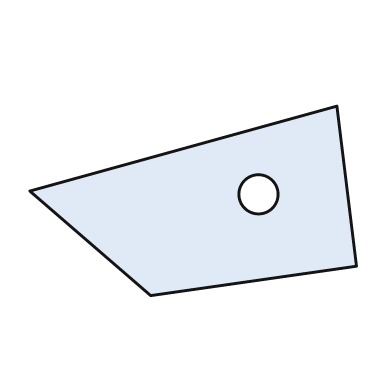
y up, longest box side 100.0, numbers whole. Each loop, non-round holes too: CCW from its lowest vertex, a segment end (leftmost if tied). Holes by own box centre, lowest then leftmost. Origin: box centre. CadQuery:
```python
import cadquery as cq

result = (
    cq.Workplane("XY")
    .moveTo(-13.0, -29.0)
    .lineTo(50.0, -20.0)
    .lineTo(44.0, 29.0)
    .lineTo(-50.0, 3.0)
    .close()
    .moveTo(20.0, 2.0)
    .circle(6.0)
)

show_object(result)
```